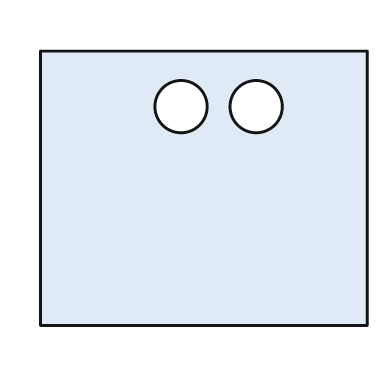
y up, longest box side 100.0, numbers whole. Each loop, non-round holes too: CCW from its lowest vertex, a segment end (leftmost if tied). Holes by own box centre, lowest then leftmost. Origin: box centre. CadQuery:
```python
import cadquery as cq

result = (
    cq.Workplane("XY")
    .moveTo(-50.0, -42.0)
    .lineTo(50.0, -42.0)
    .lineTo(50.0, 42.0)
    .lineTo(-50.0, 42.0)
    .close()
    .moveTo(-7.0, 25.0)
    .circle(8.0)
    .moveTo(16.0, 25.0)
    .circle(8.0)
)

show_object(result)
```